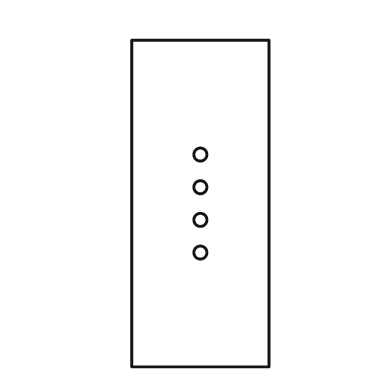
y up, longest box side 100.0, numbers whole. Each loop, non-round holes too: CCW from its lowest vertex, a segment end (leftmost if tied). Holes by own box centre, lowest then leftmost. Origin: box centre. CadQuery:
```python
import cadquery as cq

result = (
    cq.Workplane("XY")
    .moveTo(-21.0, -50.0)
    .lineTo(21.0, -50.0)
    .lineTo(21.0, 50.0)
    .lineTo(-21.0, 50.0)
    .close()
    .moveTo(0.0, -15.0)
    .circle(2.0)
    .moveTo(0.0, -5.0)
    .circle(2.0)
    .moveTo(0.0, 5.0)
    .circle(2.0)
    .moveTo(0.0, 15.0)
    .circle(2.0)
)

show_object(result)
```